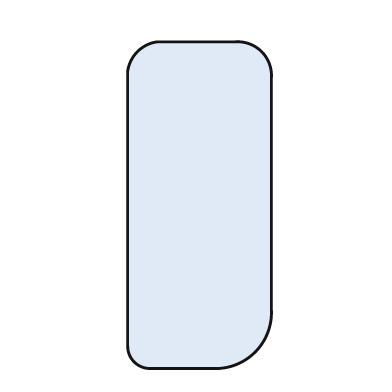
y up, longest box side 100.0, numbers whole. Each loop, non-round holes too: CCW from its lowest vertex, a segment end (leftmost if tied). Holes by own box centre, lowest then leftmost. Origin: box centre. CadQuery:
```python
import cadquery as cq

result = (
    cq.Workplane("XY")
    .moveTo(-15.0, -50.0)
    .lineTo(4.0, -50.0)
    .threePointArc((17.0, -45.0), (22.0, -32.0))
    .lineTo(22.0, 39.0)
    .threePointArc((19.0, 47.0), (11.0, 50.0))
    .lineTo(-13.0, 50.0)
    .threePointArc((-19.0, 47.0), (-22.0, 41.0))
    .lineTo(-22.0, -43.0)
    .threePointArc((-20.0, -48.0), (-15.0, -50.0))
    .close()
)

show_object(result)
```